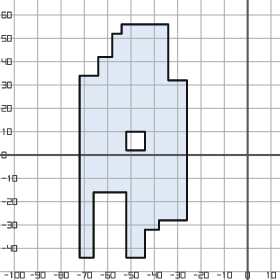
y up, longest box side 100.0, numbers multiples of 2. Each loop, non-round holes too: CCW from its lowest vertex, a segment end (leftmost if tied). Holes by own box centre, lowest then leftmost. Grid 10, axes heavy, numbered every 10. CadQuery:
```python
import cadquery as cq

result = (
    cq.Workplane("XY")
    .moveTo(-72.0, -44.0)
    .lineTo(-66.0, -44.0)
    .lineTo(-66.0, -16.0)
    .lineTo(-52.0, -16.0)
    .lineTo(-52.0, -44.0)
    .lineTo(-44.0, -44.0)
    .lineTo(-44.0, -32.0)
    .lineTo(-38.0, -32.0)
    .lineTo(-38.0, -28.0)
    .lineTo(-26.0, -28.0)
    .lineTo(-26.0, 32.0)
    .lineTo(-34.0, 32.0)
    .lineTo(-34.0, 56.0)
    .lineTo(-54.0, 56.0)
    .lineTo(-54.0, 52.0)
    .lineTo(-58.0, 52.0)
    .lineTo(-58.0, 42.0)
    .lineTo(-64.0, 42.0)
    .lineTo(-64.0, 34.0)
    .lineTo(-72.0, 34.0)
    .close()
    .moveTo(-52.0, 2.0)
    .lineTo(-44.0, 2.0)
    .lineTo(-44.0, 10.0)
    .lineTo(-52.0, 10.0)
    .close()
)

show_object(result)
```